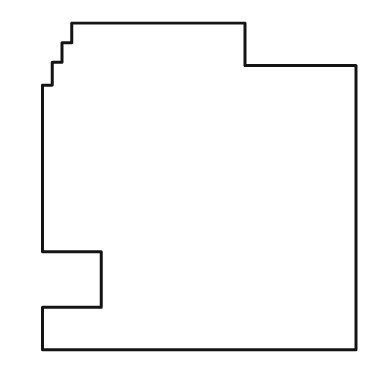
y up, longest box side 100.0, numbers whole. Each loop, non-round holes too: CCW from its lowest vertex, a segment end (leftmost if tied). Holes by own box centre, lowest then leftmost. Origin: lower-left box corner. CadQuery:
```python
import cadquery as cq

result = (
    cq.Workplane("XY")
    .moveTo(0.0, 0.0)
    .lineTo(96.0, 0.0)
    .lineTo(96.0, 87.0)
    .lineTo(62.0, 87.0)
    .lineTo(62.0, 100.0)
    .lineTo(9.0, 100.0)
    .lineTo(9.0, 94.0)
    .lineTo(6.0, 94.0)
    .lineTo(6.0, 88.0)
    .lineTo(3.0, 88.0)
    .lineTo(3.0, 81.0)
    .lineTo(0.0, 81.0)
    .lineTo(0.0, 30.0)
    .lineTo(18.0, 30.0)
    .lineTo(18.0, 13.0)
    .lineTo(0.0, 13.0)
    .close()
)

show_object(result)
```